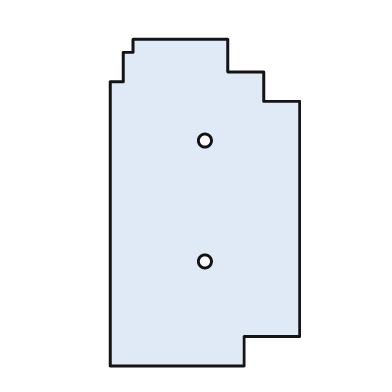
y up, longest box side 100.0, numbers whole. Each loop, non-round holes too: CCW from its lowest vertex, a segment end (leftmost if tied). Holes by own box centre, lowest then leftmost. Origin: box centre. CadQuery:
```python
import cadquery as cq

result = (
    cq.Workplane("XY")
    .moveTo(-29.0, -50.0)
    .lineTo(12.0, -50.0)
    .lineTo(12.0, -41.0)
    .lineTo(29.0, -41.0)
    .lineTo(29.0, 31.0)
    .lineTo(18.0, 31.0)
    .lineTo(18.0, 40.0)
    .lineTo(7.0, 40.0)
    .lineTo(7.0, 50.0)
    .lineTo(-22.0, 50.0)
    .lineTo(-22.0, 46.0)
    .lineTo(-25.0, 46.0)
    .lineTo(-25.0, 37.0)
    .lineTo(-29.0, 37.0)
    .close()
    .moveTo(0.0, -18.0)
    .circle(2.0)
    .moveTo(0.0, 19.0)
    .circle(2.0)
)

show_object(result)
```